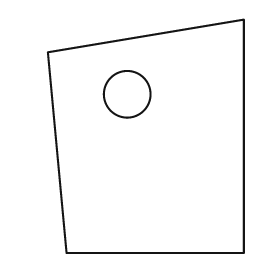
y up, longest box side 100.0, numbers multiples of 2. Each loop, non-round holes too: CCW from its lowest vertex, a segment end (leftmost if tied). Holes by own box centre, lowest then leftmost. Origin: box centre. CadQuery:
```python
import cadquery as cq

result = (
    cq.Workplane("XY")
    .moveTo(-34.0, -50.0)
    .lineTo(42.0, -50.0)
    .lineTo(42.0, 50.0)
    .lineTo(-42.0, 36.0)
    .close()
    .moveTo(-8.0, 18.0)
    .circle(10.0)
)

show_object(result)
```